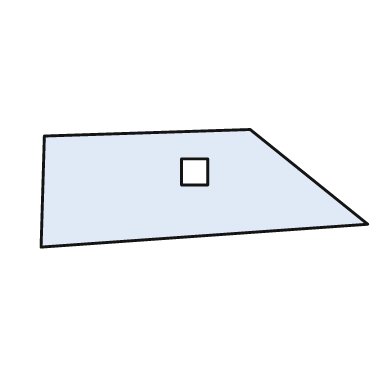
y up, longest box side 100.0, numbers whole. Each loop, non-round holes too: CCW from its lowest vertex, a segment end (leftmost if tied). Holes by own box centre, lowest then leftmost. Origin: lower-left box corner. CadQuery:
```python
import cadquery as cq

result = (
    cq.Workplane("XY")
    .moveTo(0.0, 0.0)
    .lineTo(100.0, 7.0)
    .lineTo(64.0, 36.0)
    .lineTo(1.0, 34.0)
    .close()
    .moveTo(43.0, 19.0)
    .lineTo(51.0, 19.0)
    .lineTo(51.0, 27.0)
    .lineTo(43.0, 27.0)
    .close()
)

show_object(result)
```